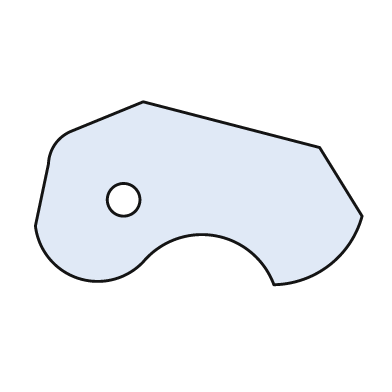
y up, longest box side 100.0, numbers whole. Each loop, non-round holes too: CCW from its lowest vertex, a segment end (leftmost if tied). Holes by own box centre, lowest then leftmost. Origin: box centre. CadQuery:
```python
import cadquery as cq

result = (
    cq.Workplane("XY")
    .moveTo(23.0, -28.0)
    .threePointArc((40.0, -22.0), (50.0, -7.0))
    .lineTo(37.0, 14.0)
    .lineTo(-17.0, 28.0)
    .lineTo(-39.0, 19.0)
    .threePointArc((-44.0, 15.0), (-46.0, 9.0))
    .lineTo(-50.0, -10.0)
    .threePointArc((-37.0, -26.0), (-17.0, -21.0))
    .threePointArc((5.0, -13.0), (23.0, -28.0))
    .close()
    .moveTo(-23.0, -2.0)
    .circle(5.0)
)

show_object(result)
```